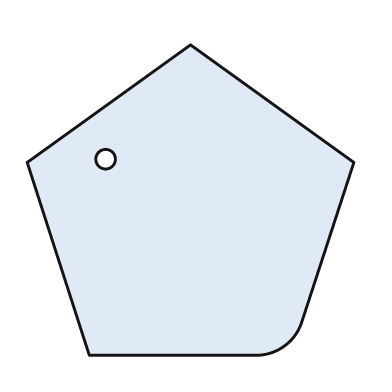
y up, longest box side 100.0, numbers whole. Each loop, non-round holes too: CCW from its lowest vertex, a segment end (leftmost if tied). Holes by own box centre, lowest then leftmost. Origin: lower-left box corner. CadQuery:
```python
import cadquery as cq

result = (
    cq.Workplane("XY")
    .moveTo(19.0, 0.0)
    .lineTo(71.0, 0.0)
    .threePointArc((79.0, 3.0), (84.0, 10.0))
    .lineTo(100.0, 59.0)
    .lineTo(50.0, 95.0)
    .lineTo(0.0, 59.0)
    .close()
    .moveTo(24.0, 60.0)
    .circle(3.0)
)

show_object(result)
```